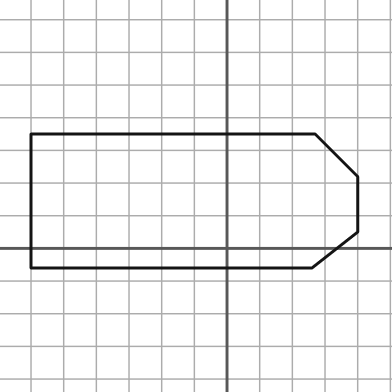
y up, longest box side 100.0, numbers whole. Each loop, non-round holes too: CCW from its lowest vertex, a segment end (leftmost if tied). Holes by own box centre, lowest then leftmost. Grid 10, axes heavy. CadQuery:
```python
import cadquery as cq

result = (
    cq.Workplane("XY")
    .moveTo(-60.0, -6.0)
    .lineTo(26.0, -6.0)
    .lineTo(40.0, 5.0)
    .lineTo(40.0, 22.0)
    .lineTo(27.0, 35.0)
    .lineTo(-60.0, 35.0)
    .close()
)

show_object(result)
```